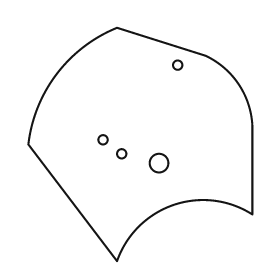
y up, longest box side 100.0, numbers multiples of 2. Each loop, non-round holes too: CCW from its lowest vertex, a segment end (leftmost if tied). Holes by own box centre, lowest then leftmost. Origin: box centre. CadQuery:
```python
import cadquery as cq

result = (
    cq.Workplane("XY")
    .moveTo(-10.0, -50.0)
    .threePointArc((14.0, -26.0), (48.0, -30.0))
    .lineTo(48.0, 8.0)
    .threePointArc((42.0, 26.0), (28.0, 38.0))
    .lineTo(-10.0, 50.0)
    .threePointArc((-36.0, 30.0), (-48.0, 0.0))
    .close()
    .moveTo(8.0, -8.0)
    .circle(4.0)
    .moveTo(-8.0, -4.0)
    .circle(2.0)
    .moveTo(-16.0, 2.0)
    .circle(2.0)
    .moveTo(16.0, 34.0)
    .circle(2.0)
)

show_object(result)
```